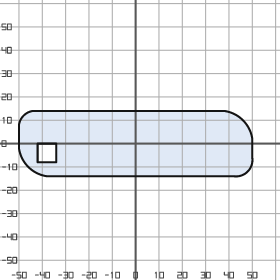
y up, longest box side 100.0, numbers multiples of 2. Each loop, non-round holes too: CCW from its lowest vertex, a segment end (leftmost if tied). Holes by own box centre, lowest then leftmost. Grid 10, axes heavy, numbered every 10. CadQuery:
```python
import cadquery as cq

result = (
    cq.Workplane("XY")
    .moveTo(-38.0, -14.0)
    .lineTo(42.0, -14.0)
    .threePointArc((48.0, -12.0), (50.0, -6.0))
    .lineTo(50.0, 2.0)
    .threePointArc((46.0, 10.0), (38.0, 14.0))
    .lineTo(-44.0, 14.0)
    .threePointArc((-48.0, 12.0), (-50.0, 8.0))
    .lineTo(-50.0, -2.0)
    .threePointArc((-46.0, -10.0), (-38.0, -14.0))
    .close()
    .moveTo(-42.0, -8.0)
    .lineTo(-34.0, -8.0)
    .lineTo(-34.0, 0.0)
    .lineTo(-42.0, 0.0)
    .close()
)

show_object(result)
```